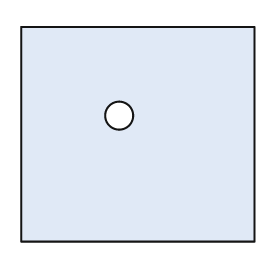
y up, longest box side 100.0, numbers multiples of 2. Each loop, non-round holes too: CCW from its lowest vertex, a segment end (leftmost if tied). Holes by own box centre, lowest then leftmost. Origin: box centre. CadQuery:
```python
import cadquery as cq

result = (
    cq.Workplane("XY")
    .moveTo(-50.0, -46.0)
    .lineTo(50.0, -46.0)
    .lineTo(50.0, 46.0)
    .lineTo(-50.0, 46.0)
    .close()
    .moveTo(-8.0, 8.0)
    .circle(6.0)
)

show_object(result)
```